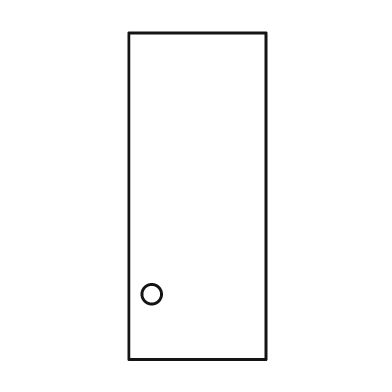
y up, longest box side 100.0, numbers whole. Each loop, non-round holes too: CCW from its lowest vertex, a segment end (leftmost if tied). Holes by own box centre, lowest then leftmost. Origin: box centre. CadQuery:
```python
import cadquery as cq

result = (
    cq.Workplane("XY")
    .moveTo(-21.0, -50.0)
    .lineTo(21.0, -50.0)
    .lineTo(21.0, 50.0)
    .lineTo(-21.0, 50.0)
    .close()
    .moveTo(-14.0, -30.0)
    .circle(3.0)
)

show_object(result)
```